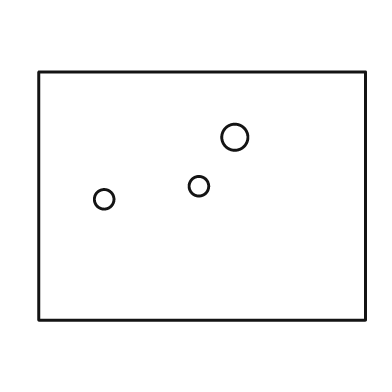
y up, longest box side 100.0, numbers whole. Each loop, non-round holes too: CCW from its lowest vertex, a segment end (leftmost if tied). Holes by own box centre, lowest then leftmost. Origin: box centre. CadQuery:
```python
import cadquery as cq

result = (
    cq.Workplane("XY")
    .moveTo(-50.0, -38.0)
    .lineTo(50.0, -38.0)
    .lineTo(50.0, 38.0)
    .lineTo(-50.0, 38.0)
    .close()
    .moveTo(-30.0, -1.0)
    .circle(3.0)
    .moveTo(-1.0, 3.0)
    .circle(3.0)
    .moveTo(10.0, 18.0)
    .circle(4.0)
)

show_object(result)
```